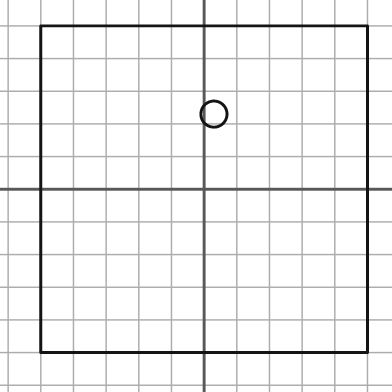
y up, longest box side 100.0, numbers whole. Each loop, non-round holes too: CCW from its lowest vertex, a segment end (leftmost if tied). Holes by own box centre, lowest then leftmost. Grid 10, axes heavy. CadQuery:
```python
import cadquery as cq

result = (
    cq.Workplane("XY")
    .moveTo(-50.0, -50.0)
    .lineTo(50.0, -50.0)
    .lineTo(50.0, 50.0)
    .lineTo(-50.0, 50.0)
    .close()
    .moveTo(3.0, 23.0)
    .circle(4.0)
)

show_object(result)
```